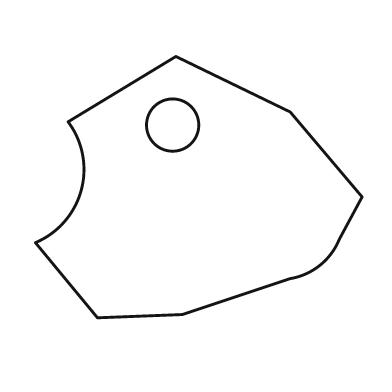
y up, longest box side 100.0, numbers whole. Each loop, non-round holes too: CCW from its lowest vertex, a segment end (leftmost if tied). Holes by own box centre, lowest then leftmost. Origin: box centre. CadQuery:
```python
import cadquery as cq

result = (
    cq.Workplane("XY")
    .moveTo(-31.0, -40.0)
    .lineTo(-5.0, -39.0)
    .lineTo(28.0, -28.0)
    .threePointArc((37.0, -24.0), (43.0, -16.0))
    .lineTo(50.0, -3.0)
    .lineTo(28.0, 23.0)
    .lineTo(-7.0, 40.0)
    .lineTo(-40.0, 20.0)
    .threePointArc((-36.0, -1.0), (-50.0, -17.0))
    .close()
    .moveTo(-8.0, 19.0)
    .circle(8.0)
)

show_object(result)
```